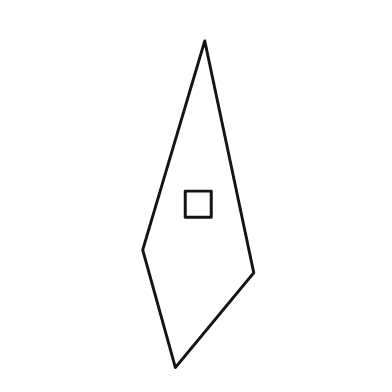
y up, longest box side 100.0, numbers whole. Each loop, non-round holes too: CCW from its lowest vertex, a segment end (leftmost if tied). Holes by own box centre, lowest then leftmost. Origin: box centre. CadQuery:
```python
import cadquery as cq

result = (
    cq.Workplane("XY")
    .moveTo(-7.0, -50.0)
    .lineTo(17.0, -21.0)
    .lineTo(2.0, 50.0)
    .lineTo(-17.0, -14.0)
    .close()
    .moveTo(-4.0, -4.0)
    .lineTo(4.0, -4.0)
    .lineTo(4.0, 4.0)
    .lineTo(-4.0, 4.0)
    .close()
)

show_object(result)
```